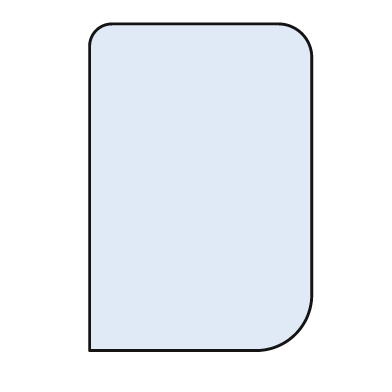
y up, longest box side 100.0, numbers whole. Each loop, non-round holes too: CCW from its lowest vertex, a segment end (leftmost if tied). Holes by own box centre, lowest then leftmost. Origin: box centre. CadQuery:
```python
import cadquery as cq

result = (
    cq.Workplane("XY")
    .moveTo(-34.0, -50.0)
    .lineTo(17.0, -50.0)
    .threePointArc((29.0, -45.0), (34.0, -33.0))
    .lineTo(34.0, 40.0)
    .threePointArc((31.0, 47.0), (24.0, 50.0))
    .lineTo(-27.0, 50.0)
    .threePointArc((-32.0, 48.0), (-34.0, 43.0))
    .close()
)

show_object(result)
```